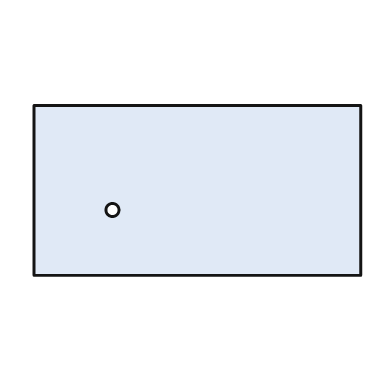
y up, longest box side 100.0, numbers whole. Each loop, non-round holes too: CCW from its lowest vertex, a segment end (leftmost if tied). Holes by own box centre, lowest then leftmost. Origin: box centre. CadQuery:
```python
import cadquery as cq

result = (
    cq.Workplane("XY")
    .moveTo(-50.0, -26.0)
    .lineTo(50.0, -26.0)
    .lineTo(50.0, 26.0)
    .lineTo(-50.0, 26.0)
    .close()
    .moveTo(-26.0, -6.0)
    .circle(2.0)
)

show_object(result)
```